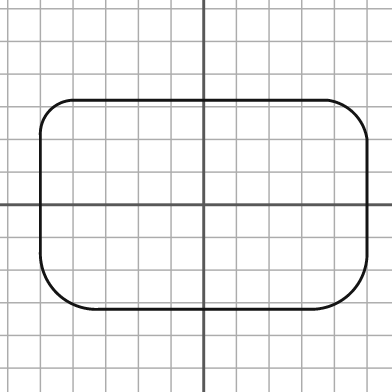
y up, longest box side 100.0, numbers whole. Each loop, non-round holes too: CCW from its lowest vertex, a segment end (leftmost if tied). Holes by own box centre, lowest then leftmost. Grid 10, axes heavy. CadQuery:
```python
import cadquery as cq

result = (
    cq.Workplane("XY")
    .moveTo(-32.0, -32.0)
    .lineTo(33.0, -32.0)
    .threePointArc((45.0, -27.0), (50.0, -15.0))
    .lineTo(50.0, 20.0)
    .threePointArc((46.0, 28.0), (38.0, 32.0))
    .lineTo(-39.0, 32.0)
    .threePointArc((-47.0, 29.0), (-50.0, 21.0))
    .lineTo(-50.0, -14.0)
    .threePointArc((-45.0, -27.0), (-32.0, -32.0))
    .close()
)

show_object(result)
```